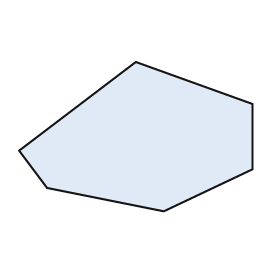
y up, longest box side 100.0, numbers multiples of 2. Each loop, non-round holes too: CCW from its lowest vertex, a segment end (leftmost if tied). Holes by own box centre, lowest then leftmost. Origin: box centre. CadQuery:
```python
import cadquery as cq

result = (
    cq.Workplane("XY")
    .moveTo(12.0, -32.0)
    .lineTo(50.0, -14.0)
    .lineTo(50.0, 14.0)
    .lineTo(0.0, 32.0)
    .lineTo(-50.0, -6.0)
    .lineTo(-38.0, -22.0)
    .close()
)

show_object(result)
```